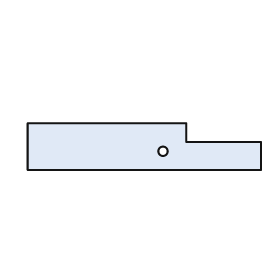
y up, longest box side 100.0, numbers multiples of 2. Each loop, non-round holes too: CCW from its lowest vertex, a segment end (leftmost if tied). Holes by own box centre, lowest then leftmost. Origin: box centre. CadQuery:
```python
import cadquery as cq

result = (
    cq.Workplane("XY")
    .moveTo(-50.0, -10.0)
    .lineTo(50.0, -10.0)
    .lineTo(50.0, 2.0)
    .lineTo(18.0, 2.0)
    .lineTo(18.0, 10.0)
    .lineTo(-50.0, 10.0)
    .close()
    .moveTo(8.0, -2.0)
    .circle(2.0)
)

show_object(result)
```